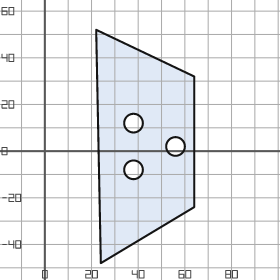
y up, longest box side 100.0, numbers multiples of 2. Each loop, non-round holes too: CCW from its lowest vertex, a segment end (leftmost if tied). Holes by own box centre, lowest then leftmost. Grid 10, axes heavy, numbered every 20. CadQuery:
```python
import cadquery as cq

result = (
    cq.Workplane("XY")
    .moveTo(24.0, -48.0)
    .lineTo(64.0, -24.0)
    .lineTo(64.0, 32.0)
    .lineTo(22.0, 52.0)
    .close()
    .moveTo(38.0, -8.0)
    .circle(4.0)
    .moveTo(56.0, 2.0)
    .circle(4.0)
    .moveTo(38.0, 12.0)
    .circle(4.0)
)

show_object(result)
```